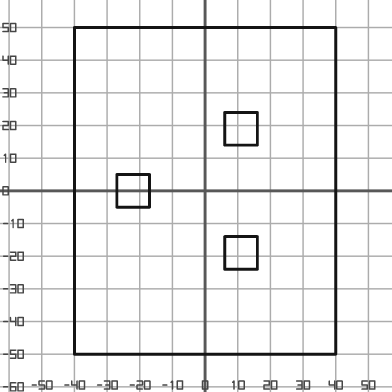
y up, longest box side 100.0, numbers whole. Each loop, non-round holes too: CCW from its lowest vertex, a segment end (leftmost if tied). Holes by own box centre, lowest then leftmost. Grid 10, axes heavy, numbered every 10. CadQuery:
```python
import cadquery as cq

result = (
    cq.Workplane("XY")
    .moveTo(-40.0, -50.0)
    .lineTo(40.0, -50.0)
    .lineTo(40.0, 50.0)
    .lineTo(-40.0, 50.0)
    .close()
    .moveTo(6.0, -24.0)
    .lineTo(16.0, -24.0)
    .lineTo(16.0, -14.0)
    .lineTo(6.0, -14.0)
    .close()
    .moveTo(-27.0, -5.0)
    .lineTo(-17.0, -5.0)
    .lineTo(-17.0, 5.0)
    .lineTo(-27.0, 5.0)
    .close()
    .moveTo(6.0, 14.0)
    .lineTo(16.0, 14.0)
    .lineTo(16.0, 24.0)
    .lineTo(6.0, 24.0)
    .close()
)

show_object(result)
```